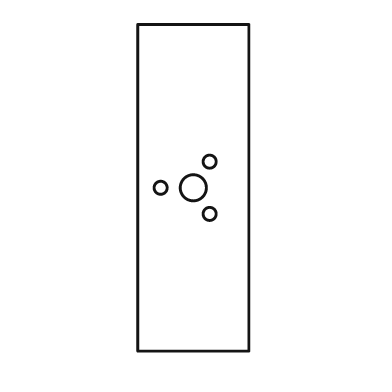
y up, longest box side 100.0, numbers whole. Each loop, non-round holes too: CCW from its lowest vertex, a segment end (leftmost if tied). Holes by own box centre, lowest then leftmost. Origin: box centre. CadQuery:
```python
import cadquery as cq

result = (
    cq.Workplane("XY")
    .moveTo(-17.0, -50.0)
    .lineTo(17.0, -50.0)
    .lineTo(17.0, 50.0)
    .lineTo(-17.0, 50.0)
    .close()
    .moveTo(5.0, -8.0)
    .circle(2.0)
    .moveTo(-10.0, 0.0)
    .circle(2.0)
    .moveTo(0.0, 0.0)
    .circle(4.0)
    .moveTo(5.0, 8.0)
    .circle(2.0)
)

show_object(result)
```